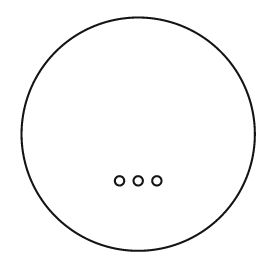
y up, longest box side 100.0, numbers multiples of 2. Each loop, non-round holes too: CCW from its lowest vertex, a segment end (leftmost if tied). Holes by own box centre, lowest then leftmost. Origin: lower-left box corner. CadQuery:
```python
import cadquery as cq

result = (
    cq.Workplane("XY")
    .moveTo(50.0, 50.0)
    .circle(50.0)
    .moveTo(42.0, 30.0)
    .circle(2.0)
    .moveTo(50.0, 30.0)
    .circle(2.0)
    .moveTo(58.0, 30.0)
    .circle(2.0)
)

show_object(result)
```